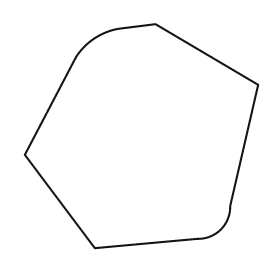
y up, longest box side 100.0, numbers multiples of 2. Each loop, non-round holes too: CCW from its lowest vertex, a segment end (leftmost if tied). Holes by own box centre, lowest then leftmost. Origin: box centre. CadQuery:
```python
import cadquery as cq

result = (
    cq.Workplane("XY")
    .moveTo(-20.0, -48.0)
    .lineTo(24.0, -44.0)
    .threePointArc((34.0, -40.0), (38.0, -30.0))
    .lineTo(50.0, 22.0)
    .lineTo(6.0, 48.0)
    .lineTo(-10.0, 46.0)
    .threePointArc((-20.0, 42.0), (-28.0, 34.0))
    .lineTo(-50.0, -8.0)
    .close()
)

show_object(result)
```